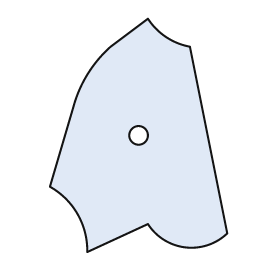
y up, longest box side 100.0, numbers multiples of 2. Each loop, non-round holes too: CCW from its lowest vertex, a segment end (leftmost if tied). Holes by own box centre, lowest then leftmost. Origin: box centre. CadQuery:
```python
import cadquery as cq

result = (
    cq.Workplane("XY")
    .moveTo(-22.0, -50.0)
    .lineTo(4.0, -38.0)
    .threePointArc((20.0, -48.0), (38.0, -42.0))
    .lineTo(22.0, 38.0)
    .threePointArc((12.0, 42.0), (4.0, 50.0))
    .lineTo(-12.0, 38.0)
    .threePointArc((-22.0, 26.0), (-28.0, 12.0))
    .lineTo(-38.0, -22.0)
    .threePointArc((-26.0, -34.0), (-22.0, -50.0))
    .close()
    .moveTo(0.0, 0.0)
    .circle(4.0)
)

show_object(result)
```